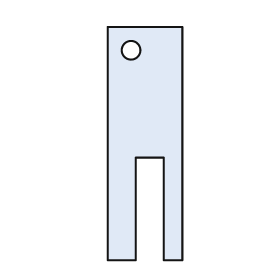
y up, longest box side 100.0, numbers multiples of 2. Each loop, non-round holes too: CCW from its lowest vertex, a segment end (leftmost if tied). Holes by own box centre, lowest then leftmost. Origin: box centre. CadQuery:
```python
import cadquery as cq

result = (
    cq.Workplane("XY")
    .moveTo(-16.0, -50.0)
    .lineTo(-4.0, -50.0)
    .lineTo(-4.0, -6.0)
    .lineTo(8.0, -6.0)
    .lineTo(8.0, -50.0)
    .lineTo(16.0, -50.0)
    .lineTo(16.0, 50.0)
    .lineTo(-16.0, 50.0)
    .close()
    .moveTo(-6.0, 40.0)
    .circle(4.0)
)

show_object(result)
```